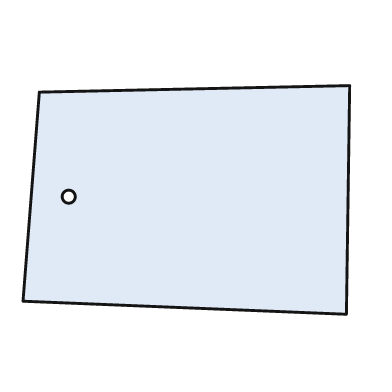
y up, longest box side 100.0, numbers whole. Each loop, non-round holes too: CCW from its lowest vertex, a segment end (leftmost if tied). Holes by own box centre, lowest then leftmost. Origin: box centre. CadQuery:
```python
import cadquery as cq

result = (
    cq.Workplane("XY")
    .moveTo(49.0, -35.0)
    .lineTo(50.0, 35.0)
    .lineTo(-45.0, 33.0)
    .lineTo(-50.0, -31.0)
    .close()
    .moveTo(-36.0, 1.0)
    .circle(2.0)
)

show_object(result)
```